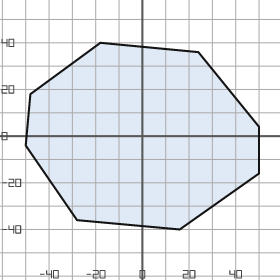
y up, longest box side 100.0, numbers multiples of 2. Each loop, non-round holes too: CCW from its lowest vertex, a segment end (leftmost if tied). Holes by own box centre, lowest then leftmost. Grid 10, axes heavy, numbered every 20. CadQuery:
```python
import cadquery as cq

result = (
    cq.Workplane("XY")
    .moveTo(16.0, -40.0)
    .lineTo(50.0, -16.0)
    .lineTo(50.0, 4.0)
    .lineTo(24.0, 36.0)
    .lineTo(-18.0, 40.0)
    .lineTo(-48.0, 18.0)
    .lineTo(-50.0, -4.0)
    .lineTo(-28.0, -36.0)
    .close()
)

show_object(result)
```